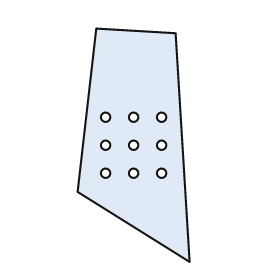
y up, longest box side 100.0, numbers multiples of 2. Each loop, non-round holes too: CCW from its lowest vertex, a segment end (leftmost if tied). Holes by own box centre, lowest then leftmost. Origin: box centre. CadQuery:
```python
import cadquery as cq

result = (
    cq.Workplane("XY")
    .moveTo(24.0, -50.0)
    .lineTo(18.0, 48.0)
    .lineTo(-16.0, 50.0)
    .lineTo(-24.0, -20.0)
    .close()
    .moveTo(-12.0, -12.0)
    .circle(2.0)
    .moveTo(0.0, -12.0)
    .circle(2.0)
    .moveTo(12.0, -12.0)
    .circle(2.0)
    .moveTo(-12.0, 0.0)
    .circle(2.0)
    .moveTo(0.0, 0.0)
    .circle(2.0)
    .moveTo(12.0, 0.0)
    .circle(2.0)
    .moveTo(-12.0, 12.0)
    .circle(2.0)
    .moveTo(0.0, 12.0)
    .circle(2.0)
    .moveTo(12.0, 12.0)
    .circle(2.0)
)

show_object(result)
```